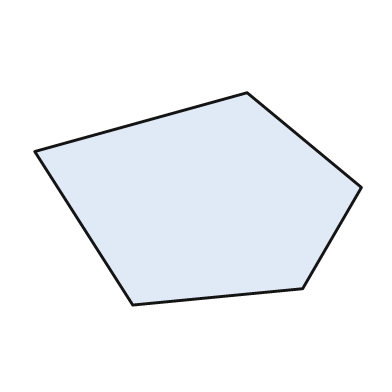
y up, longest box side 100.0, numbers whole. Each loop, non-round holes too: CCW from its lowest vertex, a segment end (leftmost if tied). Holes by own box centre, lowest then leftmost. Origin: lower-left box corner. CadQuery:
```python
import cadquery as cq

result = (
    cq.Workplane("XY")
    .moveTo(30.0, 0.0)
    .lineTo(82.0, 5.0)
    .lineTo(100.0, 36.0)
    .lineTo(65.0, 65.0)
    .lineTo(0.0, 47.0)
    .close()
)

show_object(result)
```